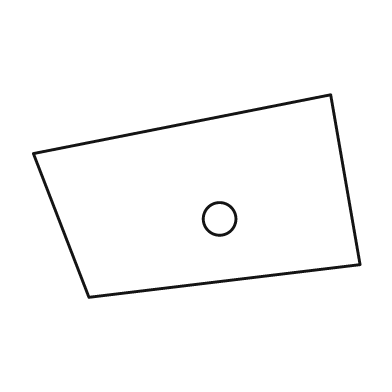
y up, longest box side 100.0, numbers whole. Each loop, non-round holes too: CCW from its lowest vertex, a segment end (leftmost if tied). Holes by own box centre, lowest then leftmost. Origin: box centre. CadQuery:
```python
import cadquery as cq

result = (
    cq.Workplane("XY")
    .moveTo(-33.0, -31.0)
    .lineTo(50.0, -21.0)
    .lineTo(41.0, 31.0)
    .lineTo(-50.0, 13.0)
    .close()
    .moveTo(7.0, -7.0)
    .circle(5.0)
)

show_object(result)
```